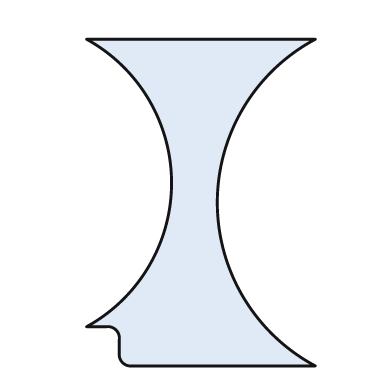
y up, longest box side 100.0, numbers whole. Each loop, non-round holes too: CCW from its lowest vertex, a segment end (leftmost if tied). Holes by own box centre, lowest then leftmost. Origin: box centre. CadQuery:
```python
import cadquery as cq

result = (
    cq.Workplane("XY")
    .moveTo(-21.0, -50.0)
    .lineTo(35.0, -50.0)
    .threePointArc((5.0, 0.0), (35.0, 50.0))
    .lineTo(-35.0, 50.0)
    .threePointArc((-9.0, 6.0), (-35.0, -38.0))
    .lineTo(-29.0, -38.0)
    .threePointArc((-26.0, -39.0), (-25.0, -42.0))
    .lineTo(-25.0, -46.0)
    .threePointArc((-24.0, -49.0), (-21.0, -50.0))
    .close()
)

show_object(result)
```